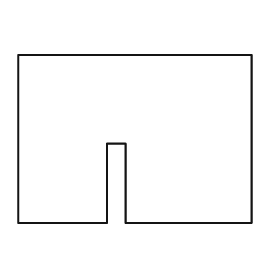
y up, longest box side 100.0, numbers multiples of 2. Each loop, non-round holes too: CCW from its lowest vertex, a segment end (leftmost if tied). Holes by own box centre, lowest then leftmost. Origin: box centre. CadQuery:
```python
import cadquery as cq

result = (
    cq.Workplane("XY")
    .moveTo(-50.0, -36.0)
    .lineTo(-12.0, -36.0)
    .lineTo(-12.0, -2.0)
    .lineTo(-4.0, -2.0)
    .lineTo(-4.0, -36.0)
    .lineTo(50.0, -36.0)
    .lineTo(50.0, 36.0)
    .lineTo(-50.0, 36.0)
    .close()
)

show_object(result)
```